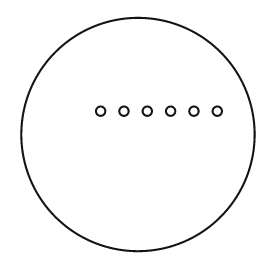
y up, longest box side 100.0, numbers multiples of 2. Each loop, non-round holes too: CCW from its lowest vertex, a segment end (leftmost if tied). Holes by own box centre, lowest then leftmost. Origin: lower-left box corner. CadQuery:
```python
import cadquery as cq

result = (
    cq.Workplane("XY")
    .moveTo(50.0, 50.0)
    .circle(50.0)
    .moveTo(34.0, 60.0)
    .circle(2.0)
    .moveTo(44.0, 60.0)
    .circle(2.0)
    .moveTo(54.0, 60.0)
    .circle(2.0)
    .moveTo(64.0, 60.0)
    .circle(2.0)
    .moveTo(74.0, 60.0)
    .circle(2.0)
    .moveTo(84.0, 60.0)
    .circle(2.0)
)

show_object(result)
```